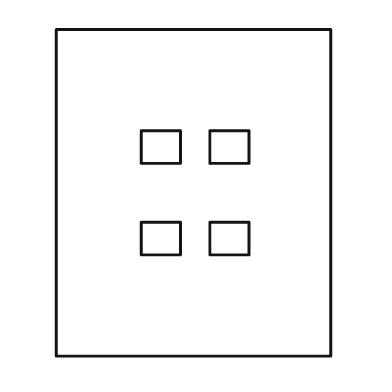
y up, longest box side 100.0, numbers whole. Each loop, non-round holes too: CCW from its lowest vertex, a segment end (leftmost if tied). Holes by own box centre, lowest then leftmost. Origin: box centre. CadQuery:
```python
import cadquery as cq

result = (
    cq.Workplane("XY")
    .moveTo(-42.0, -50.0)
    .lineTo(42.0, -50.0)
    .lineTo(42.0, 50.0)
    .lineTo(-42.0, 50.0)
    .close()
    .moveTo(-16.0, -19.0)
    .lineTo(-4.0, -19.0)
    .lineTo(-4.0, -9.0)
    .lineTo(-16.0, -9.0)
    .close()
    .moveTo(5.0, -19.0)
    .lineTo(17.0, -19.0)
    .lineTo(17.0, -9.0)
    .lineTo(5.0, -9.0)
    .close()
    .moveTo(-16.0, 9.0)
    .lineTo(-4.0, 9.0)
    .lineTo(-4.0, 19.0)
    .lineTo(-16.0, 19.0)
    .close()
    .moveTo(5.0, 9.0)
    .lineTo(17.0, 9.0)
    .lineTo(17.0, 19.0)
    .lineTo(5.0, 19.0)
    .close()
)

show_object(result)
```